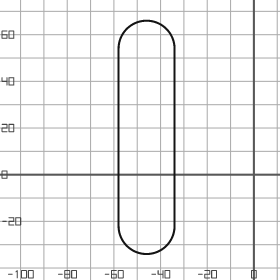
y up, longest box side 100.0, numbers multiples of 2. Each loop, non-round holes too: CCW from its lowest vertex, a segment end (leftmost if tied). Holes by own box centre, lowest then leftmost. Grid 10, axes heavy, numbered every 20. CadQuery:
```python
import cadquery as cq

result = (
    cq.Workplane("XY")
    .moveTo(-58.0, -22.0)
    .threePointArc((-46.0, -34.0), (-34.0, -22.0))
    .lineTo(-34.0, 54.0)
    .threePointArc((-46.0, 66.0), (-58.0, 54.0))
    .close()
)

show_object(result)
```